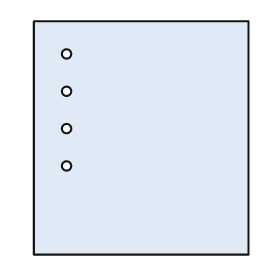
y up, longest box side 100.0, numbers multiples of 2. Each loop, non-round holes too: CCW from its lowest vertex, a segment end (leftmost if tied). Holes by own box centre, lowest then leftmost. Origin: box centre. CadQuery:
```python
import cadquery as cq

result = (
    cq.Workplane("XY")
    .moveTo(-46.0, -50.0)
    .lineTo(46.0, -50.0)
    .lineTo(46.0, 50.0)
    .lineTo(-46.0, 50.0)
    .close()
    .moveTo(-32.0, -12.0)
    .circle(2.0)
    .moveTo(-32.0, 4.0)
    .circle(2.0)
    .moveTo(-32.0, 20.0)
    .circle(2.0)
    .moveTo(-32.0, 36.0)
    .circle(2.0)
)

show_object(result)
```